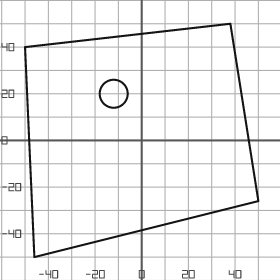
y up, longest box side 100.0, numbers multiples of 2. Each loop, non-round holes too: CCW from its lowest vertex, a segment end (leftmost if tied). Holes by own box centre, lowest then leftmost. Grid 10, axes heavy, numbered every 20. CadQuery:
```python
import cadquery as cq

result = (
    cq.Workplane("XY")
    .moveTo(-46.0, -50.0)
    .lineTo(50.0, -26.0)
    .lineTo(38.0, 50.0)
    .lineTo(-50.0, 40.0)
    .close()
    .moveTo(-12.0, 20.0)
    .circle(6.0)
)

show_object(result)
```